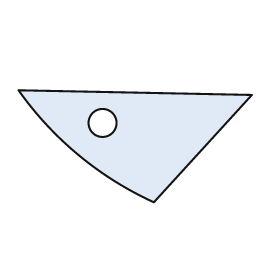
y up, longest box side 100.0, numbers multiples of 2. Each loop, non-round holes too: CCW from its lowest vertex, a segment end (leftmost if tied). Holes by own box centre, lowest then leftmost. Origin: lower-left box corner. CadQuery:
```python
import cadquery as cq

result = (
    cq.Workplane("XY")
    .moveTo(58.0, 0.0)
    .lineTo(100.0, 46.0)
    .lineTo(0.0, 48.0)
    .threePointArc((26.0, 20.0), (58.0, 0.0))
    .close()
    .moveTo(36.0, 34.0)
    .circle(6.0)
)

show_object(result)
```